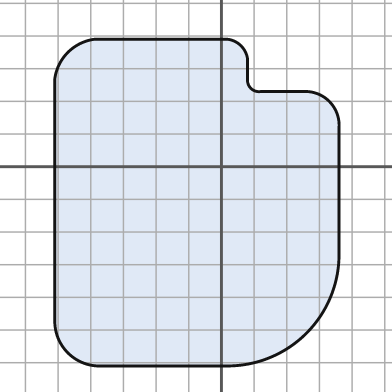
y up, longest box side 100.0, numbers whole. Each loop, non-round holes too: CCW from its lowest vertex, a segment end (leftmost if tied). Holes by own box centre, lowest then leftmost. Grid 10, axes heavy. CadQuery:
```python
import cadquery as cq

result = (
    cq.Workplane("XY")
    .moveTo(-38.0, -61.0)
    .lineTo(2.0, -61.0)
    .threePointArc((26.0, -51.0), (36.0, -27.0))
    .lineTo(36.0, 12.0)
    .threePointArc((33.0, 20.0), (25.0, 23.0))
    .lineTo(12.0, 23.0)
    .threePointArc((9.0, 24.0), (8.0, 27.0))
    .lineTo(8.0, 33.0)
    .threePointArc((6.0, 37.0), (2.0, 39.0))
    .lineTo(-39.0, 39.0)
    .threePointArc((-47.0, 35.0), (-51.0, 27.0))
    .lineTo(-51.0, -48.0)
    .threePointArc((-47.0, -57.0), (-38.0, -61.0))
    .close()
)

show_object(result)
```